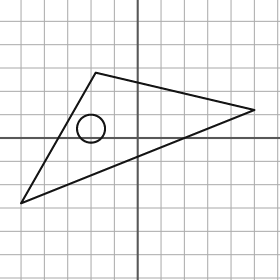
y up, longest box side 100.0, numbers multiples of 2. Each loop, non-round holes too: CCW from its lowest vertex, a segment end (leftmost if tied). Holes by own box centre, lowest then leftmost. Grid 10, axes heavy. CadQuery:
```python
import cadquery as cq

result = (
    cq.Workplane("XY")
    .moveTo(-50.0, -28.0)
    .lineTo(50.0, 12.0)
    .lineTo(-18.0, 28.0)
    .close()
    .moveTo(-20.0, 4.0)
    .circle(6.0)
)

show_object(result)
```